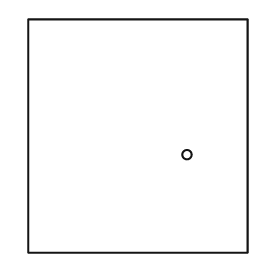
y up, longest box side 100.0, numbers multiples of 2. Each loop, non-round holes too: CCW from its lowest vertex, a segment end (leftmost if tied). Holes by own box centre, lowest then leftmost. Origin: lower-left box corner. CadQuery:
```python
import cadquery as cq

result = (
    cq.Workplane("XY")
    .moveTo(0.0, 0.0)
    .lineTo(94.0, 0.0)
    .lineTo(94.0, 100.0)
    .lineTo(0.0, 100.0)
    .close()
    .moveTo(68.0, 42.0)
    .circle(2.0)
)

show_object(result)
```